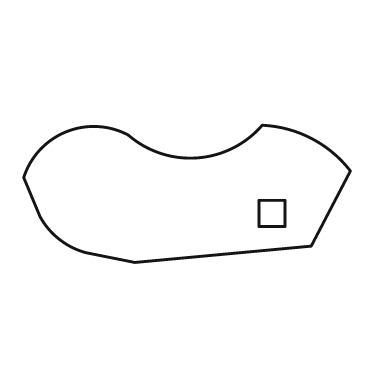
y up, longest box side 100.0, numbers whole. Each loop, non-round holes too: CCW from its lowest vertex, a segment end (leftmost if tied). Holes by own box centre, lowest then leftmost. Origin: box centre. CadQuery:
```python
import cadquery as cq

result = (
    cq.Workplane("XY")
    .moveTo(-16.0, -21.0)
    .lineTo(38.0, -16.0)
    .lineTo(50.0, 7.0)
    .threePointArc((38.0, 17.0), (23.0, 21.0))
    .threePointArc((3.0, 11.0), (-18.0, 18.0))
    .threePointArc((-37.0, 19.0), (-50.0, 5.0))
    .lineTo(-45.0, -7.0)
    .threePointArc((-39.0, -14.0), (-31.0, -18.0))
    .close()
    .moveTo(22.0, -10.0)
    .lineTo(30.0, -10.0)
    .lineTo(30.0, -2.0)
    .lineTo(22.0, -2.0)
    .close()
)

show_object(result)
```